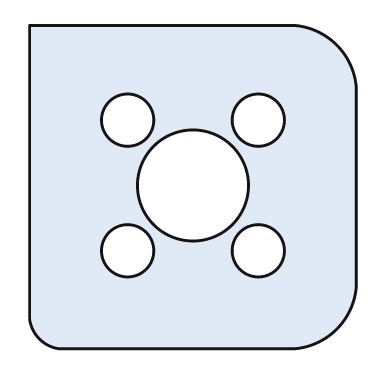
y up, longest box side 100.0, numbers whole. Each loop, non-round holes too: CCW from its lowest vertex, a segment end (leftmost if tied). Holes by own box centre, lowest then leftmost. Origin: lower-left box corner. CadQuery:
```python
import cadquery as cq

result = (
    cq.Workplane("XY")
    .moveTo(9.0, 0.0)
    .lineTo(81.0, 0.0)
    .threePointArc((94.0, 6.0), (100.0, 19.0))
    .lineTo(100.0, 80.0)
    .threePointArc((94.0, 93.0), (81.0, 99.0))
    .lineTo(0.0, 99.0)
    .lineTo(0.0, 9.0)
    .threePointArc((3.0, 3.0), (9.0, 0.0))
    .close()
    .moveTo(30.0, 30.0)
    .circle(8.0)
    .moveTo(70.0, 30.0)
    .circle(8.0)
    .moveTo(50.0, 50.0)
    .circle(17.0)
    .moveTo(30.0, 70.0)
    .circle(8.0)
    .moveTo(70.0, 70.0)
    .circle(8.0)
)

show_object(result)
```